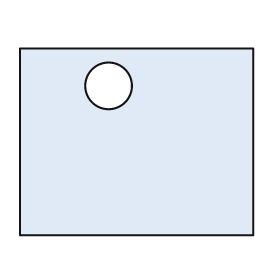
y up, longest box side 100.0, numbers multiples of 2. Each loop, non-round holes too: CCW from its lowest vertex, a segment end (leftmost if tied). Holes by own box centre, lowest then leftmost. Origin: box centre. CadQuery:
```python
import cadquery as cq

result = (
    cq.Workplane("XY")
    .moveTo(-50.0, -40.0)
    .lineTo(50.0, -40.0)
    .lineTo(50.0, 40.0)
    .lineTo(-50.0, 40.0)
    .close()
    .moveTo(-12.0, 24.0)
    .circle(10.0)
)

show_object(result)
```